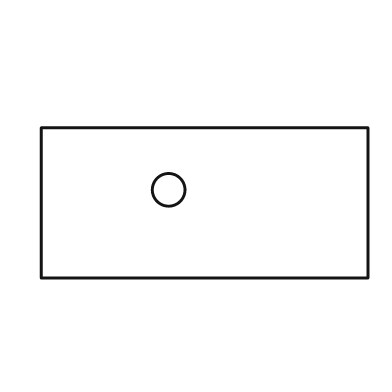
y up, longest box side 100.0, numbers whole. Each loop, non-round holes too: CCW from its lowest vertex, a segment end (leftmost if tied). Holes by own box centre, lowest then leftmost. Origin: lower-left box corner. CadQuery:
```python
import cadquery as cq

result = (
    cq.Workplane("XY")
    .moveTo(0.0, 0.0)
    .lineTo(100.0, 0.0)
    .lineTo(100.0, 46.0)
    .lineTo(0.0, 46.0)
    .close()
    .moveTo(39.0, 27.0)
    .circle(5.0)
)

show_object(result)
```